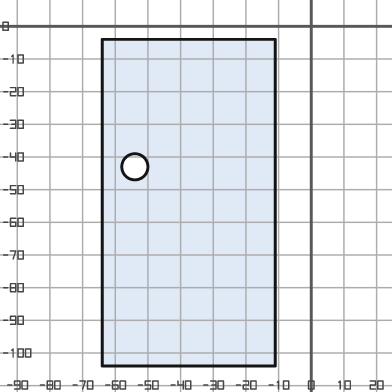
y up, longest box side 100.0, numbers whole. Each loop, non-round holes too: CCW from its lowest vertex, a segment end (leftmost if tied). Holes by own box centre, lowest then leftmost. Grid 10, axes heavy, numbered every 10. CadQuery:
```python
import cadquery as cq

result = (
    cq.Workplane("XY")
    .moveTo(-64.0, -104.0)
    .lineTo(-11.0, -104.0)
    .lineTo(-11.0, -4.0)
    .lineTo(-64.0, -4.0)
    .close()
    .moveTo(-54.0, -43.0)
    .circle(4.0)
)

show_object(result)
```